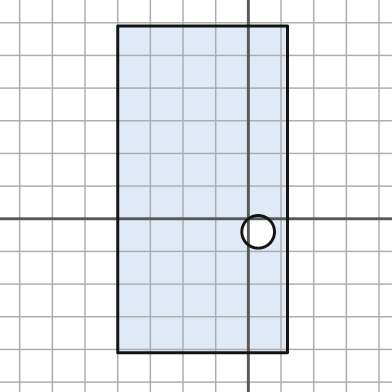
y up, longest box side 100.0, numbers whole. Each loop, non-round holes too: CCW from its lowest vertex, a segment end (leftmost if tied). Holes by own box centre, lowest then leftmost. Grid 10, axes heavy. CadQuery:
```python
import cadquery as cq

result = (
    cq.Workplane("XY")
    .moveTo(-40.0, -41.0)
    .lineTo(12.0, -41.0)
    .lineTo(12.0, 59.0)
    .lineTo(-40.0, 59.0)
    .close()
    .moveTo(3.0, -4.0)
    .circle(5.0)
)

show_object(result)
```